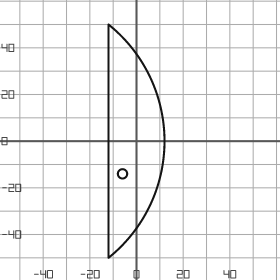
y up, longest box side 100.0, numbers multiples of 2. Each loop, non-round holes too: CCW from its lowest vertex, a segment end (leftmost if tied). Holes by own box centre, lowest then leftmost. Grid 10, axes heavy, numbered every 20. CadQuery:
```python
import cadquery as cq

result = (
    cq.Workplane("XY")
    .moveTo(-12.0, -50.0)
    .threePointArc((12.0, 0.0), (-12.0, 50.0))
    .close()
    .moveTo(-6.0, -14.0)
    .circle(2.0)
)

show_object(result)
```